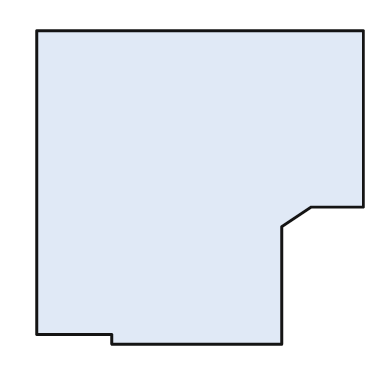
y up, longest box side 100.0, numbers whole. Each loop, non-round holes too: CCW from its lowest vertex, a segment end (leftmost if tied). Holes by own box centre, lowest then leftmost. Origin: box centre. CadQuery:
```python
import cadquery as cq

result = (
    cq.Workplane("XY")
    .moveTo(-27.0, -48.0)
    .lineTo(25.0, -48.0)
    .lineTo(25.0, -12.0)
    .lineTo(34.0, -6.0)
    .lineTo(50.0, -6.0)
    .lineTo(50.0, 48.0)
    .lineTo(-50.0, 48.0)
    .lineTo(-50.0, -45.0)
    .lineTo(-27.0, -45.0)
    .close()
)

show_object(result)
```